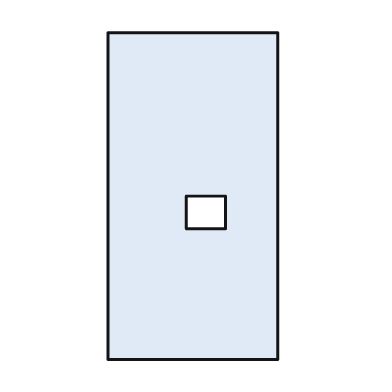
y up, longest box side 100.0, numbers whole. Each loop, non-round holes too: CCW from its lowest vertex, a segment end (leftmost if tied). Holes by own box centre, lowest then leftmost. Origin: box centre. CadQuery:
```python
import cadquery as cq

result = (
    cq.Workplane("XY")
    .moveTo(-26.0, -50.0)
    .lineTo(26.0, -50.0)
    .lineTo(26.0, 50.0)
    .lineTo(-26.0, 50.0)
    .close()
    .moveTo(-2.0, -10.0)
    .lineTo(10.0, -10.0)
    .lineTo(10.0, 0.0)
    .lineTo(-2.0, 0.0)
    .close()
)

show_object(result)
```